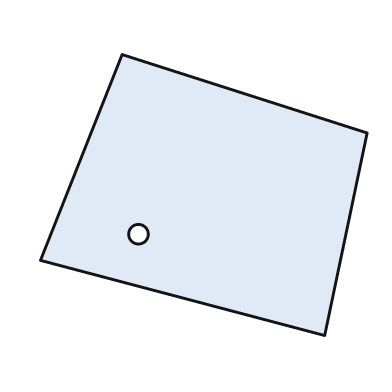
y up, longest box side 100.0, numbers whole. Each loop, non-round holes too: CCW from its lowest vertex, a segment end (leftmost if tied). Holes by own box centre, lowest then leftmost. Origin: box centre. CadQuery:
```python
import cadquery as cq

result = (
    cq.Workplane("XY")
    .moveTo(37.0, -43.0)
    .lineTo(50.0, 19.0)
    .lineTo(-25.0, 43.0)
    .lineTo(-50.0, -20.0)
    .close()
    .moveTo(-20.0, -12.0)
    .circle(3.0)
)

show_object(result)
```